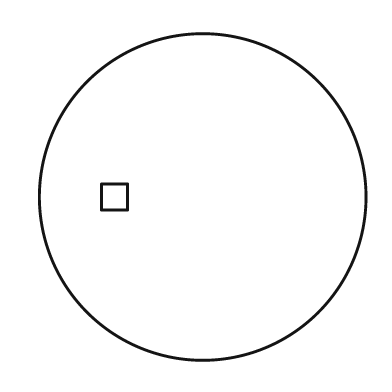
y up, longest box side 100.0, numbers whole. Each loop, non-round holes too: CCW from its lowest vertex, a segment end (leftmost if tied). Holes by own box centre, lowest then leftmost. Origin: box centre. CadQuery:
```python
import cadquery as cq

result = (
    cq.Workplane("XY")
    .moveTo(0.0, 0.0)
    .circle(50.0)
    .moveTo(-31.0, -4.0)
    .lineTo(-23.0, -4.0)
    .lineTo(-23.0, 4.0)
    .lineTo(-31.0, 4.0)
    .close()
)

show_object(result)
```